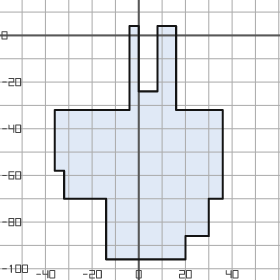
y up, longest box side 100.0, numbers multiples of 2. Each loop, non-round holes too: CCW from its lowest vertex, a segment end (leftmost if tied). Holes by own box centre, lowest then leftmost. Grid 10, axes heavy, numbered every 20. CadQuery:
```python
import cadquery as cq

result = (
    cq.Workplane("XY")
    .moveTo(-14.0, -96.0)
    .lineTo(20.0, -96.0)
    .lineTo(20.0, -86.0)
    .lineTo(30.0, -86.0)
    .lineTo(30.0, -70.0)
    .lineTo(36.0, -70.0)
    .lineTo(36.0, -32.0)
    .lineTo(16.0, -32.0)
    .lineTo(16.0, 4.0)
    .lineTo(8.0, 4.0)
    .lineTo(8.0, -24.0)
    .lineTo(0.0, -24.0)
    .lineTo(0.0, 4.0)
    .lineTo(-4.0, 4.0)
    .lineTo(-4.0, -32.0)
    .lineTo(-36.0, -32.0)
    .lineTo(-36.0, -58.0)
    .lineTo(-32.0, -58.0)
    .lineTo(-32.0, -70.0)
    .lineTo(-14.0, -70.0)
    .close()
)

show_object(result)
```